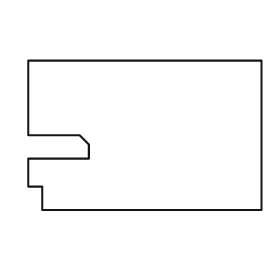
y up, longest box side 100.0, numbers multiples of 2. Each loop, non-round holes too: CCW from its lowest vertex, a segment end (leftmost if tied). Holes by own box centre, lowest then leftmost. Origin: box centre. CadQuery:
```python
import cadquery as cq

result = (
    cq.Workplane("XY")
    .moveTo(-44.0, -32.0)
    .lineTo(50.0, -32.0)
    .lineTo(50.0, 32.0)
    .lineTo(-50.0, 32.0)
    .lineTo(-50.0, 0.0)
    .lineTo(-28.0, 0.0)
    .lineTo(-24.0, -4.0)
    .lineTo(-24.0, -10.0)
    .lineTo(-50.0, -10.0)
    .lineTo(-50.0, -22.0)
    .lineTo(-44.0, -22.0)
    .close()
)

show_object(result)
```